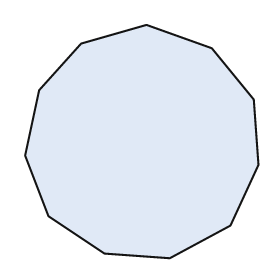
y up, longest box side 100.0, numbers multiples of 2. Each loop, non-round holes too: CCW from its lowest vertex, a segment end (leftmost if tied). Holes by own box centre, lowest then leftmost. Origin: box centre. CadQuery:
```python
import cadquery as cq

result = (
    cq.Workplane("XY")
    .moveTo(12.0, -50.0)
    .lineTo(38.0, -36.0)
    .lineTo(50.0, -10.0)
    .lineTo(48.0, 18.0)
    .lineTo(30.0, 40.0)
    .lineTo(2.0, 50.0)
    .lineTo(-26.0, 42.0)
    .lineTo(-44.0, 22.0)
    .lineTo(-50.0, -6.0)
    .lineTo(-40.0, -32.0)
    .lineTo(-16.0, -48.0)
    .close()
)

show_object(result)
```